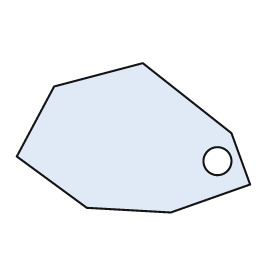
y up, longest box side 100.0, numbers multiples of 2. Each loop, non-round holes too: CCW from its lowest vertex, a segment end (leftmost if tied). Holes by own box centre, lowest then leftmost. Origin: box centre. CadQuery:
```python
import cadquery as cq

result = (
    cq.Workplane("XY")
    .moveTo(16.0, -32.0)
    .lineTo(50.0, -20.0)
    .lineTo(42.0, 2.0)
    .lineTo(4.0, 32.0)
    .lineTo(-34.0, 22.0)
    .lineTo(-50.0, -8.0)
    .lineTo(-20.0, -30.0)
    .close()
    .moveTo(36.0, -10.0)
    .circle(6.0)
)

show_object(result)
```